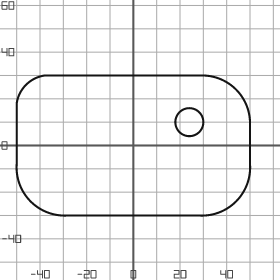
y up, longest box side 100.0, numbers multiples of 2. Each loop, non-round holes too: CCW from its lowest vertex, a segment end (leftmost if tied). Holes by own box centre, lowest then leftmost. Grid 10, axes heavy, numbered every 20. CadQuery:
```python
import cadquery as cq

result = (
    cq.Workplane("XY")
    .moveTo(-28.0, -30.0)
    .lineTo(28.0, -30.0)
    .threePointArc((44.0, -24.0), (50.0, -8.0))
    .lineTo(50.0, 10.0)
    .threePointArc((44.0, 24.0), (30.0, 30.0))
    .lineTo(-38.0, 30.0)
    .threePointArc((-46.0, 26.0), (-50.0, 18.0))
    .lineTo(-50.0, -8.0)
    .threePointArc((-44.0, -24.0), (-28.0, -30.0))
    .close()
    .moveTo(24.0, 10.0)
    .circle(6.0)
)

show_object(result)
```